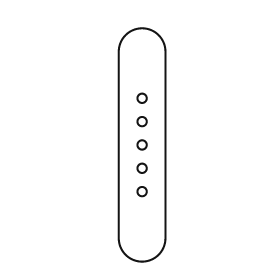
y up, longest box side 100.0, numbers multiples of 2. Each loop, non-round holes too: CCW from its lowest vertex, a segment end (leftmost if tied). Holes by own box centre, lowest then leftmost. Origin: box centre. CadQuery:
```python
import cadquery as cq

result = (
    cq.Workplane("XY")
    .moveTo(-10.0, -40.0)
    .threePointArc((0.0, -50.0), (10.0, -40.0))
    .lineTo(10.0, 40.0)
    .threePointArc((0.0, 50.0), (-10.0, 40.0))
    .close()
    .moveTo(0.0, -20.0)
    .circle(2.0)
    .moveTo(0.0, -10.0)
    .circle(2.0)
    .moveTo(0.0, 0.0)
    .circle(2.0)
    .moveTo(0.0, 10.0)
    .circle(2.0)
    .moveTo(0.0, 20.0)
    .circle(2.0)
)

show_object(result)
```